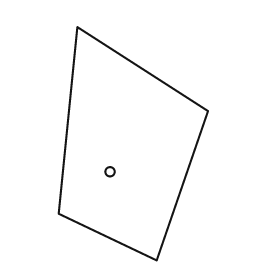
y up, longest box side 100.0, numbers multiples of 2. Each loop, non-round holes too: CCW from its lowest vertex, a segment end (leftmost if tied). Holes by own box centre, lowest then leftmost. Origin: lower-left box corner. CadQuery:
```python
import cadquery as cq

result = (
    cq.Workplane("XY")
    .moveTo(42.0, 0.0)
    .lineTo(64.0, 64.0)
    .lineTo(8.0, 100.0)
    .lineTo(0.0, 20.0)
    .close()
    .moveTo(22.0, 38.0)
    .circle(2.0)
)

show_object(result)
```